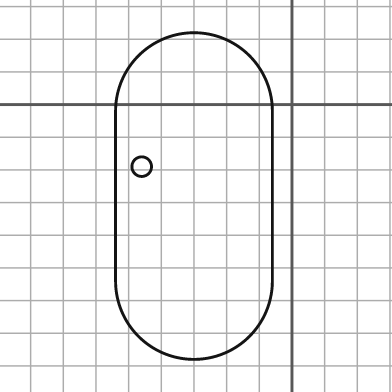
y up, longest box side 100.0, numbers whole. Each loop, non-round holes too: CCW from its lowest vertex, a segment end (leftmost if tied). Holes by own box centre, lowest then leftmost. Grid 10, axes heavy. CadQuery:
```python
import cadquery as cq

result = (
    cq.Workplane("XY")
    .moveTo(-54.0, -54.0)
    .threePointArc((-30.0, -78.0), (-6.0, -54.0))
    .lineTo(-6.0, -2.0)
    .threePointArc((-30.0, 22.0), (-54.0, -2.0))
    .close()
    .moveTo(-46.0, -19.0)
    .circle(3.0)
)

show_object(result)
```